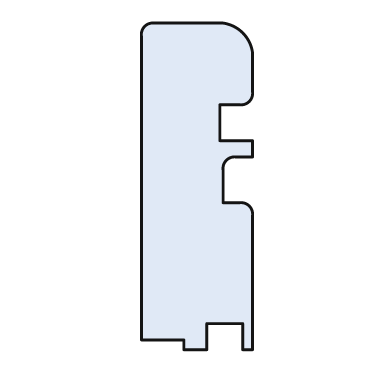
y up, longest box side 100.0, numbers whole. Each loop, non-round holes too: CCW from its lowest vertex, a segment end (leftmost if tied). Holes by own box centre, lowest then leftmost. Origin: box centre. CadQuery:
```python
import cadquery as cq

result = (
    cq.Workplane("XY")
    .moveTo(-4.0, -50.0)
    .lineTo(3.0, -50.0)
    .lineTo(3.0, -42.0)
    .lineTo(14.0, -42.0)
    .lineTo(14.0, -50.0)
    .lineTo(17.0, -50.0)
    .lineTo(17.0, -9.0)
    .threePointArc((16.0, -6.0), (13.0, -5.0))
    .lineTo(8.0, -5.0)
    .lineTo(8.0, 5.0)
    .threePointArc((9.0, 8.0), (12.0, 9.0))
    .lineTo(17.0, 9.0)
    .lineTo(17.0, 14.0)
    .lineTo(7.0, 14.0)
    .lineTo(7.0, 25.0)
    .lineTo(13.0, 25.0)
    .threePointArc((16.0, 26.0), (17.0, 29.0))
    .lineTo(17.0, 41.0)
    .threePointArc((14.0, 47.0), (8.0, 50.0))
    .lineTo(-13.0, 50.0)
    .threePointArc((-16.0, 49.0), (-17.0, 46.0))
    .lineTo(-17.0, -47.0)
    .lineTo(-4.0, -47.0)
    .close()
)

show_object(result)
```